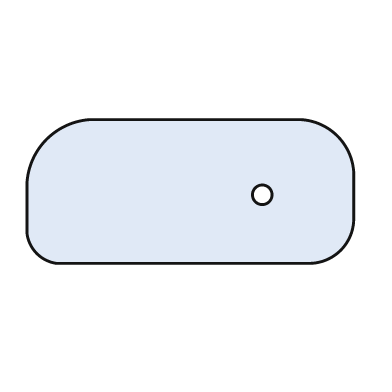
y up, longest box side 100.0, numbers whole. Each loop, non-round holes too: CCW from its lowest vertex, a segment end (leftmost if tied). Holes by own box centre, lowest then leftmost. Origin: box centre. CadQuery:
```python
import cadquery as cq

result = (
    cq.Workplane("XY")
    .moveTo(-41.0, -22.0)
    .lineTo(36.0, -22.0)
    .threePointArc((46.0, -18.0), (50.0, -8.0))
    .lineTo(50.0, 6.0)
    .threePointArc((45.0, 17.0), (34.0, 22.0))
    .lineTo(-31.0, 22.0)
    .threePointArc((-44.0, 16.0), (-50.0, 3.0))
    .lineTo(-50.0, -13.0)
    .threePointArc((-47.0, -19.0), (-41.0, -22.0))
    .close()
    .moveTo(22.0, -1.0)
    .circle(3.0)
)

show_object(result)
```